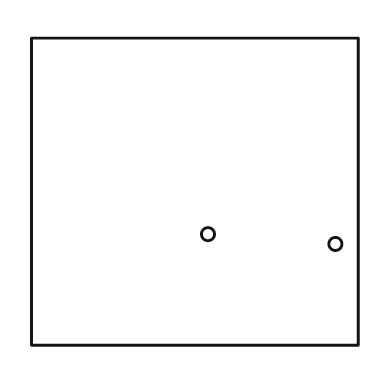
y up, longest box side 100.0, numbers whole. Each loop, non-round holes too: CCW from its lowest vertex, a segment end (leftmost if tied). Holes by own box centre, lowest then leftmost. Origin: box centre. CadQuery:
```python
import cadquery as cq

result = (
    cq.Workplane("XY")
    .moveTo(-50.0, -47.0)
    .lineTo(50.0, -47.0)
    .lineTo(50.0, 47.0)
    .lineTo(-50.0, 47.0)
    .close()
    .moveTo(43.0, -16.0)
    .circle(2.0)
    .moveTo(4.0, -13.0)
    .circle(2.0)
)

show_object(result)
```